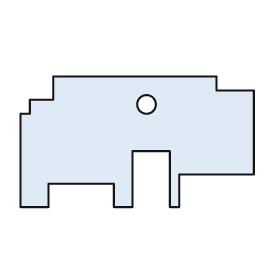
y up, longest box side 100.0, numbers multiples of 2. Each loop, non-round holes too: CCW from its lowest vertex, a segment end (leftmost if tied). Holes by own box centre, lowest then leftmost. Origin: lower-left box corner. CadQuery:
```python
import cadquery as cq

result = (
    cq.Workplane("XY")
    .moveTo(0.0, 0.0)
    .lineTo(12.0, 0.0)
    .lineTo(12.0, 10.0)
    .lineTo(40.0, 10.0)
    .lineTo(40.0, 0.0)
    .lineTo(48.0, 0.0)
    .lineTo(48.0, 24.0)
    .lineTo(64.0, 24.0)
    .lineTo(64.0, 0.0)
    .lineTo(68.0, 0.0)
    .lineTo(68.0, 14.0)
    .lineTo(100.0, 14.0)
    .lineTo(100.0, 50.0)
    .lineTo(84.0, 50.0)
    .lineTo(84.0, 56.0)
    .lineTo(14.0, 56.0)
    .lineTo(14.0, 46.0)
    .lineTo(4.0, 46.0)
    .lineTo(4.0, 40.0)
    .lineTo(0.0, 40.0)
    .close()
    .moveTo(54.0, 44.0)
    .circle(4.0)
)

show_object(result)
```